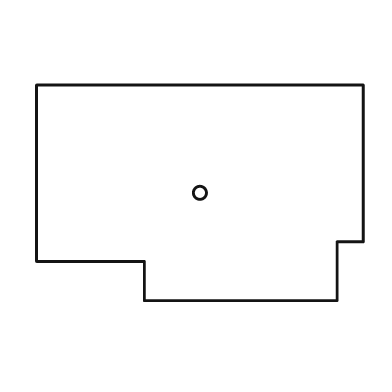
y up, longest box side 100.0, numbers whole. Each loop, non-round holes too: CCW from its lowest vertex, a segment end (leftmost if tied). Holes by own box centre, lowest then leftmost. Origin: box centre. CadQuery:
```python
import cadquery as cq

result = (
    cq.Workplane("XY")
    .moveTo(-17.0, -33.0)
    .lineTo(42.0, -33.0)
    .lineTo(42.0, -15.0)
    .lineTo(50.0, -15.0)
    .lineTo(50.0, 33.0)
    .lineTo(-50.0, 33.0)
    .lineTo(-50.0, -21.0)
    .lineTo(-17.0, -21.0)
    .close()
    .moveTo(0.0, 0.0)
    .circle(2.0)
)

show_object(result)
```